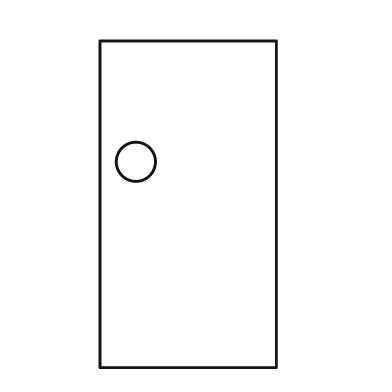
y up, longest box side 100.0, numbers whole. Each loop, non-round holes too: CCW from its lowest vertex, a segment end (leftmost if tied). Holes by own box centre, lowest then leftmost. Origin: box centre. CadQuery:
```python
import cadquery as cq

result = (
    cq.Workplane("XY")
    .moveTo(-27.0, -50.0)
    .lineTo(27.0, -50.0)
    .lineTo(27.0, 50.0)
    .lineTo(-27.0, 50.0)
    .close()
    .moveTo(-16.0, 13.0)
    .circle(6.0)
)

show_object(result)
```